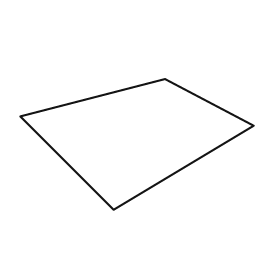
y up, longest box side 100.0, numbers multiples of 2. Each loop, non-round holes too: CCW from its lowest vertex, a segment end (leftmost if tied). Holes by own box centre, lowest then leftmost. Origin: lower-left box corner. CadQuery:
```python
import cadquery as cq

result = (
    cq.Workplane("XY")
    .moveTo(40.0, 0.0)
    .lineTo(100.0, 36.0)
    .lineTo(62.0, 56.0)
    .lineTo(0.0, 40.0)
    .close()
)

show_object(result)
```